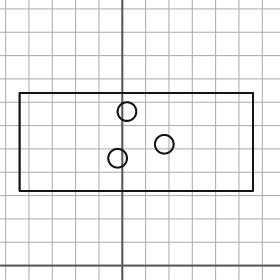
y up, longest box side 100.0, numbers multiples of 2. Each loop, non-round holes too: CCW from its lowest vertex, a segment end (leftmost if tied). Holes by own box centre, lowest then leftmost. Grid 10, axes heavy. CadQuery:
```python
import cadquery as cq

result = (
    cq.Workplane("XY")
    .moveTo(-44.0, 32.0)
    .lineTo(56.0, 32.0)
    .lineTo(56.0, 74.0)
    .lineTo(-44.0, 74.0)
    .close()
    .moveTo(-2.0, 46.0)
    .circle(4.0)
    .moveTo(18.0, 52.0)
    .circle(4.0)
    .moveTo(2.0, 66.0)
    .circle(4.0)
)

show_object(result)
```